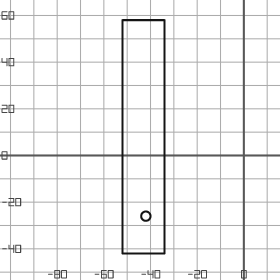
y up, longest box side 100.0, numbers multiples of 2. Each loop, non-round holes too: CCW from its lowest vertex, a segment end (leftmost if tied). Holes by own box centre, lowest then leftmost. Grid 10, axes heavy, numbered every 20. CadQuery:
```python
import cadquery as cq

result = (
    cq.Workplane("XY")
    .moveTo(-52.0, -42.0)
    .lineTo(-34.0, -42.0)
    .lineTo(-34.0, 58.0)
    .lineTo(-52.0, 58.0)
    .close()
    .moveTo(-42.0, -26.0)
    .circle(2.0)
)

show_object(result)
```